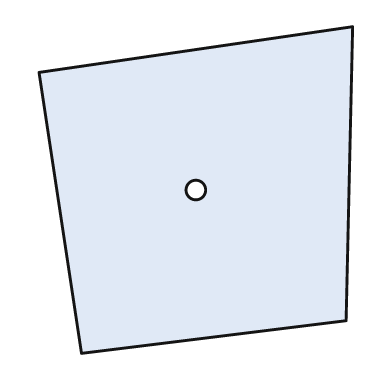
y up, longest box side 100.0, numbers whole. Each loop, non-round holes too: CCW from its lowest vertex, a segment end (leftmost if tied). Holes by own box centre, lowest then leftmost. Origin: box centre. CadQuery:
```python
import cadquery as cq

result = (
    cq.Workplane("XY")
    .moveTo(-35.0, -50.0)
    .lineTo(46.0, -40.0)
    .lineTo(48.0, 50.0)
    .lineTo(-48.0, 36.0)
    .close()
    .moveTo(0.0, 0.0)
    .circle(3.0)
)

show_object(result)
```